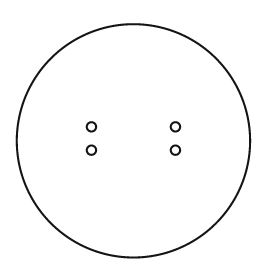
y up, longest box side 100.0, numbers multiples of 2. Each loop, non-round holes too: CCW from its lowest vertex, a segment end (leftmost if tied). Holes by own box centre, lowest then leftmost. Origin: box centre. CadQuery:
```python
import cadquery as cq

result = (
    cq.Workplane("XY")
    .moveTo(0.0, 0.0)
    .circle(50.0)
    .moveTo(-18.0, -4.0)
    .circle(2.0)
    .moveTo(18.0, -4.0)
    .circle(2.0)
    .moveTo(-18.0, 6.0)
    .circle(2.0)
    .moveTo(18.0, 6.0)
    .circle(2.0)
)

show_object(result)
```